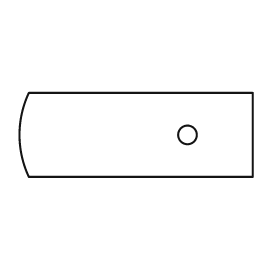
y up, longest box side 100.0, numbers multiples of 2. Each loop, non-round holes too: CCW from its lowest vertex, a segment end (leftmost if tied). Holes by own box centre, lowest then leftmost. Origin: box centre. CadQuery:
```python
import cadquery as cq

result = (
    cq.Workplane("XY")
    .moveTo(-46.0, -18.0)
    .lineTo(50.0, -18.0)
    .lineTo(50.0, 18.0)
    .lineTo(-46.0, 18.0)
    .threePointArc((-50.0, 0.0), (-46.0, -18.0))
    .close()
    .moveTo(22.0, 0.0)
    .circle(4.0)
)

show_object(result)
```